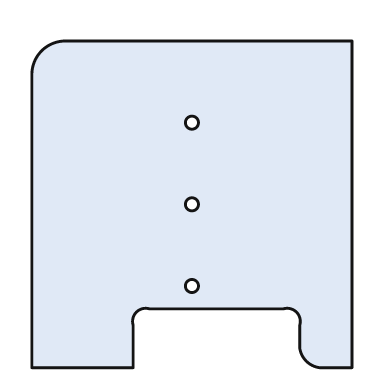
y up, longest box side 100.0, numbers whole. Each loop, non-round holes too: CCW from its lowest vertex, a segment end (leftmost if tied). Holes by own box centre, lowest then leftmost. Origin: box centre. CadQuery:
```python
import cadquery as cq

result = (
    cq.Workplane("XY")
    .moveTo(-49.0, -50.0)
    .lineTo(-18.0, -50.0)
    .lineTo(-18.0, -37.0)
    .threePointArc((-17.0, -33.0), (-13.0, -32.0))
    .lineTo(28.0, -32.0)
    .threePointArc((32.0, -33.0), (33.0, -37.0))
    .lineTo(33.0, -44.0)
    .threePointArc((35.0, -48.0), (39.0, -50.0))
    .lineTo(49.0, -50.0)
    .lineTo(49.0, 50.0)
    .lineTo(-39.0, 50.0)
    .threePointArc((-46.0, 47.0), (-49.0, 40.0))
    .close()
    .moveTo(0.0, -25.0)
    .circle(2.0)
    .moveTo(0.0, 0.0)
    .circle(2.0)
    .moveTo(0.0, 25.0)
    .circle(2.0)
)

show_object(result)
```